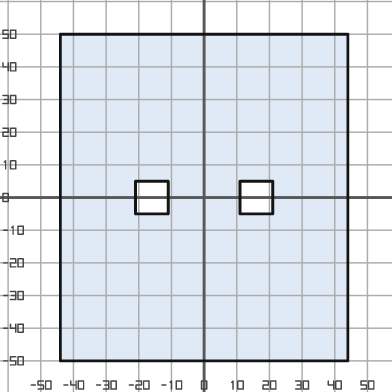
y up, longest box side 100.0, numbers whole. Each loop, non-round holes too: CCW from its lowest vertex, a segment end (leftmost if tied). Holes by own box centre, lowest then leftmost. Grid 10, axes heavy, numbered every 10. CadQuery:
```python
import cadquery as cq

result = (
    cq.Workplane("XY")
    .moveTo(-44.0, -50.0)
    .lineTo(44.0, -50.0)
    .lineTo(44.0, 50.0)
    .lineTo(-44.0, 50.0)
    .close()
    .moveTo(-21.0, -5.0)
    .lineTo(-11.0, -5.0)
    .lineTo(-11.0, 5.0)
    .lineTo(-21.0, 5.0)
    .close()
    .moveTo(11.0, -5.0)
    .lineTo(21.0, -5.0)
    .lineTo(21.0, 5.0)
    .lineTo(11.0, 5.0)
    .close()
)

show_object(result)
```